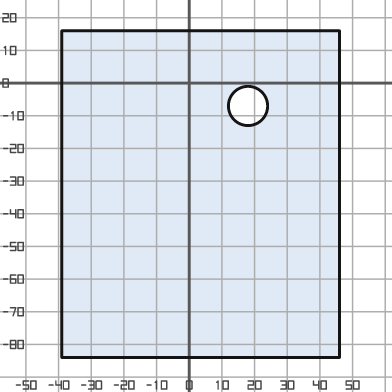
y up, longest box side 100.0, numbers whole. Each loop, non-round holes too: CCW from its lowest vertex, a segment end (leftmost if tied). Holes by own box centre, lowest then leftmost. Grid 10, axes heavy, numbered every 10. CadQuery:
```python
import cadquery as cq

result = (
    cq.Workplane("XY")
    .moveTo(-39.0, -84.0)
    .lineTo(46.0, -84.0)
    .lineTo(46.0, 16.0)
    .lineTo(-39.0, 16.0)
    .close()
    .moveTo(18.0, -7.0)
    .circle(6.0)
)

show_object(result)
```